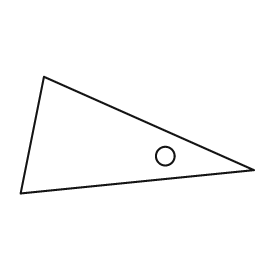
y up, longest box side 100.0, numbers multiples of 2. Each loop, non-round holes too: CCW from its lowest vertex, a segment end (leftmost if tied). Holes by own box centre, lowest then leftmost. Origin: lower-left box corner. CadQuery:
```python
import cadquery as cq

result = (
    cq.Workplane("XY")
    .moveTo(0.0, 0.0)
    .lineTo(100.0, 10.0)
    .lineTo(10.0, 50.0)
    .close()
    .moveTo(62.0, 16.0)
    .circle(4.0)
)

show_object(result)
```